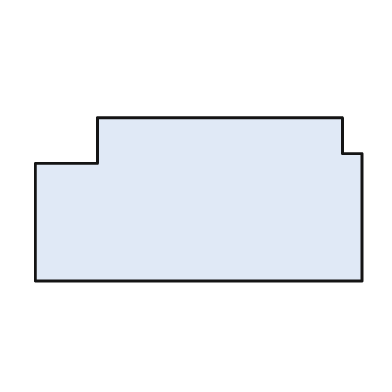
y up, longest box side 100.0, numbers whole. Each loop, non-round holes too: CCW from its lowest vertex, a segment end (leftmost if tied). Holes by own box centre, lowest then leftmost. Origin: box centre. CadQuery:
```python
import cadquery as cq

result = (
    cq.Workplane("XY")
    .moveTo(-50.0, -25.0)
    .lineTo(50.0, -25.0)
    .lineTo(50.0, 14.0)
    .lineTo(44.0, 14.0)
    .lineTo(44.0, 25.0)
    .lineTo(-31.0, 25.0)
    .lineTo(-31.0, 11.0)
    .lineTo(-50.0, 11.0)
    .close()
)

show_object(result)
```